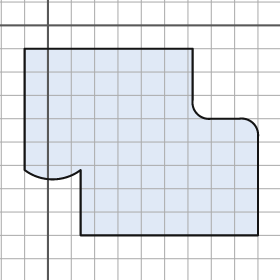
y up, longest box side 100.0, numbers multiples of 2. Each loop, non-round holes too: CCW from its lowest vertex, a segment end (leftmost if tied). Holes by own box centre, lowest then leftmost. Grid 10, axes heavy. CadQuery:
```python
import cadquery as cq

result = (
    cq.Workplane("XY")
    .moveTo(14.0, -90.0)
    .lineTo(90.0, -90.0)
    .lineTo(90.0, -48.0)
    .threePointArc((88.0, -42.0), (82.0, -40.0))
    .lineTo(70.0, -40.0)
    .threePointArc((64.0, -38.0), (62.0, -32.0))
    .lineTo(62.0, -10.0)
    .lineTo(-10.0, -10.0)
    .lineTo(-10.0, -62.0)
    .threePointArc((2.0, -66.0), (14.0, -62.0))
    .close()
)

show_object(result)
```